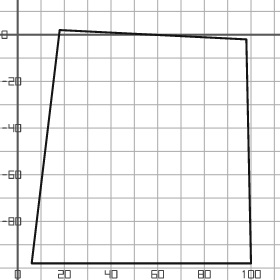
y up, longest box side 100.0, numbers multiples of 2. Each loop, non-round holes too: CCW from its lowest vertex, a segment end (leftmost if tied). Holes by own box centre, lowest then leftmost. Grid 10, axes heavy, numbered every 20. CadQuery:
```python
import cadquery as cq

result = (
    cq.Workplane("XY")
    .moveTo(6.0, -98.0)
    .lineTo(100.0, -98.0)
    .lineTo(98.0, -2.0)
    .lineTo(18.0, 2.0)
    .close()
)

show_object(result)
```